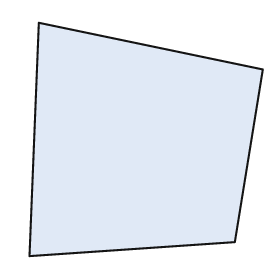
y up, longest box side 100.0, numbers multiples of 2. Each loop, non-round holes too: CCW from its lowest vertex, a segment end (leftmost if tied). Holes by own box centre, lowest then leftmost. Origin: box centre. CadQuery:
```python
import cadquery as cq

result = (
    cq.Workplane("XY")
    .moveTo(-50.0, -50.0)
    .lineTo(38.0, -44.0)
    .lineTo(50.0, 30.0)
    .lineTo(-46.0, 50.0)
    .close()
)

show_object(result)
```